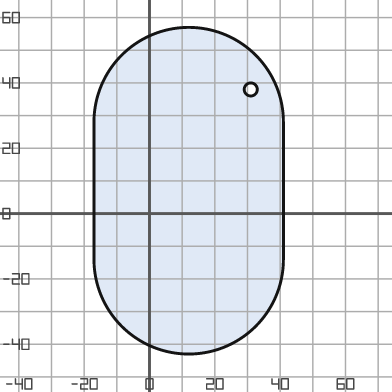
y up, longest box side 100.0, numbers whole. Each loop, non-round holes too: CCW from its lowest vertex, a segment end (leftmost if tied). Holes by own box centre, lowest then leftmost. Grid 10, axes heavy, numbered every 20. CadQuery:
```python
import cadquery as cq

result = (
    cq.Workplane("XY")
    .moveTo(-17.0, -14.0)
    .threePointArc((12.0, -43.0), (41.0, -14.0))
    .lineTo(41.0, 28.0)
    .threePointArc((12.0, 57.0), (-17.0, 28.0))
    .close()
    .moveTo(31.0, 38.0)
    .circle(2.0)
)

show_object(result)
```